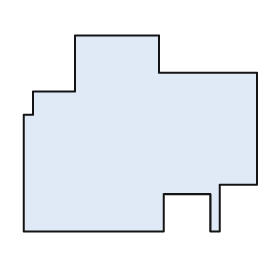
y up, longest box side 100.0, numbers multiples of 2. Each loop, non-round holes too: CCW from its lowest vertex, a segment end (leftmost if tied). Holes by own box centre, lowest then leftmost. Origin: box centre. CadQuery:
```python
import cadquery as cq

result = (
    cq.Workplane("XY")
    .moveTo(-50.0, -42.0)
    .lineTo(10.0, -42.0)
    .lineTo(10.0, -26.0)
    .lineTo(30.0, -26.0)
    .lineTo(30.0, -42.0)
    .lineTo(34.0, -42.0)
    .lineTo(34.0, -22.0)
    .lineTo(50.0, -22.0)
    .lineTo(50.0, 26.0)
    .lineTo(8.0, 26.0)
    .lineTo(8.0, 42.0)
    .lineTo(-28.0, 42.0)
    .lineTo(-28.0, 18.0)
    .lineTo(-46.0, 18.0)
    .lineTo(-46.0, 8.0)
    .lineTo(-50.0, 8.0)
    .close()
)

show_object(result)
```